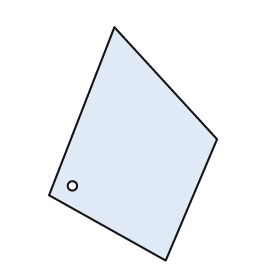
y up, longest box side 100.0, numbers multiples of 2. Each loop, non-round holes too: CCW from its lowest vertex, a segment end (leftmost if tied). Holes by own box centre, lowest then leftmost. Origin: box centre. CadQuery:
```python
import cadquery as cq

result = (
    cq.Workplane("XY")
    .moveTo(14.0, -50.0)
    .lineTo(36.0, 2.0)
    .lineTo(-8.0, 50.0)
    .lineTo(-36.0, -22.0)
    .close()
    .moveTo(-26.0, -18.0)
    .circle(2.0)
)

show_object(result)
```